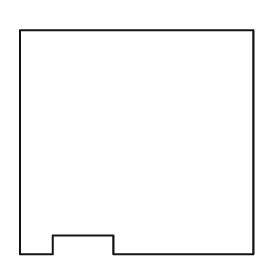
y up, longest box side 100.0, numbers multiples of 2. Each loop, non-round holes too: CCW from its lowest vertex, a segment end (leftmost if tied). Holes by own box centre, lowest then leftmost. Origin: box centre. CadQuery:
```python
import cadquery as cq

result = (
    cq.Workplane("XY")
    .moveTo(-50.0, -48.0)
    .lineTo(-36.0, -48.0)
    .lineTo(-36.0, -40.0)
    .lineTo(-10.0, -40.0)
    .lineTo(-10.0, -48.0)
    .lineTo(50.0, -48.0)
    .lineTo(50.0, 48.0)
    .lineTo(-50.0, 48.0)
    .close()
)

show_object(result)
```